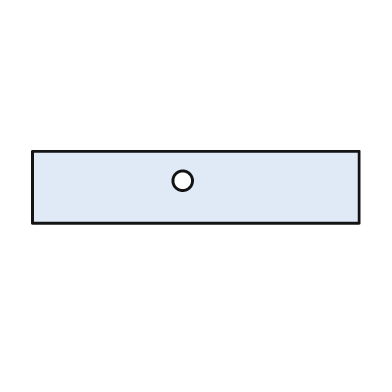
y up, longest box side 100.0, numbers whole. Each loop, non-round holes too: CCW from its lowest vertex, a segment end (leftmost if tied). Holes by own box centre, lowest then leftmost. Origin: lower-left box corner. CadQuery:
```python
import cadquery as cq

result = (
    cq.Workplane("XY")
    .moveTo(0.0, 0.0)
    .lineTo(100.0, 0.0)
    .lineTo(100.0, 22.0)
    .lineTo(0.0, 22.0)
    .close()
    .moveTo(46.0, 13.0)
    .circle(3.0)
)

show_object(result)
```